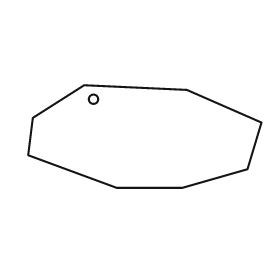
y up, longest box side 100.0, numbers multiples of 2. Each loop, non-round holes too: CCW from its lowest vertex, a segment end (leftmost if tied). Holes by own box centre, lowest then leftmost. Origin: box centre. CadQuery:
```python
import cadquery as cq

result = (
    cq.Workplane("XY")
    .moveTo(-12.0, -22.0)
    .lineTo(16.0, -22.0)
    .lineTo(44.0, -14.0)
    .lineTo(50.0, 6.0)
    .lineTo(18.0, 20.0)
    .lineTo(-26.0, 22.0)
    .lineTo(-48.0, 8.0)
    .lineTo(-50.0, -8.0)
    .close()
    .moveTo(-22.0, 16.0)
    .circle(2.0)
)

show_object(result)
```